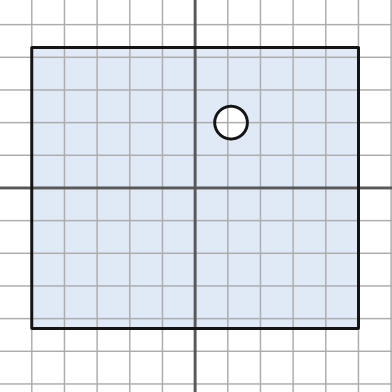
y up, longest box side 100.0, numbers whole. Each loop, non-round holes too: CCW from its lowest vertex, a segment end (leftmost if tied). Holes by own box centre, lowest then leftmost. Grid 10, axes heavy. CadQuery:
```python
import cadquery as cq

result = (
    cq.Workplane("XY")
    .moveTo(-50.0, -43.0)
    .lineTo(50.0, -43.0)
    .lineTo(50.0, 43.0)
    .lineTo(-50.0, 43.0)
    .close()
    .moveTo(11.0, 20.0)
    .circle(5.0)
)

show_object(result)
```